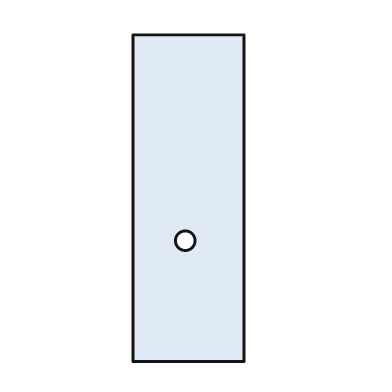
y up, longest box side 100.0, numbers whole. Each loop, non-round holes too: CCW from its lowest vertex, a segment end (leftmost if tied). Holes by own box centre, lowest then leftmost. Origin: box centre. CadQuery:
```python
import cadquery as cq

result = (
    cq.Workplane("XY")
    .moveTo(-17.0, -50.0)
    .lineTo(17.0, -50.0)
    .lineTo(17.0, 50.0)
    .lineTo(-17.0, 50.0)
    .close()
    .moveTo(-1.0, -13.0)
    .circle(3.0)
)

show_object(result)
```